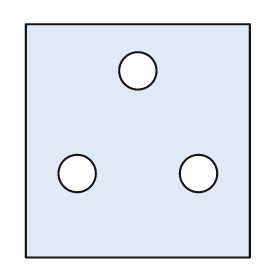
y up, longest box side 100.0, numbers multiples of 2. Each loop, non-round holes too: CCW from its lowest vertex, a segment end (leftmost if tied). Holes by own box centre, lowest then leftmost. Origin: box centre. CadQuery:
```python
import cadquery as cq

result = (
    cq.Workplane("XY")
    .moveTo(-48.0, -50.0)
    .lineTo(48.0, -50.0)
    .lineTo(48.0, 50.0)
    .lineTo(-48.0, 50.0)
    .close()
    .moveTo(-26.0, -14.0)
    .circle(8.0)
    .moveTo(26.0, -14.0)
    .circle(8.0)
    .moveTo(0.0, 30.0)
    .circle(8.0)
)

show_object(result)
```